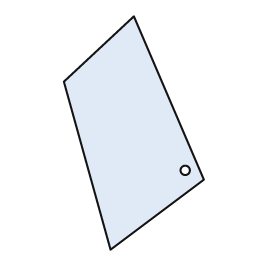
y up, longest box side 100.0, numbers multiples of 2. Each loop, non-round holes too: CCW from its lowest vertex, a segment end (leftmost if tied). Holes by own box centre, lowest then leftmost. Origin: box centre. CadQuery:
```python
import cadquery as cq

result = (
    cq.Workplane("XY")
    .moveTo(-10.0, -50.0)
    .lineTo(30.0, -20.0)
    .lineTo(0.0, 50.0)
    .lineTo(-30.0, 22.0)
    .close()
    .moveTo(22.0, -16.0)
    .circle(2.0)
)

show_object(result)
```